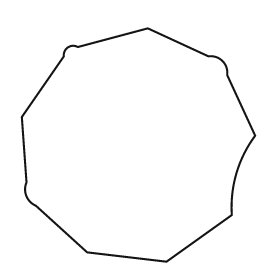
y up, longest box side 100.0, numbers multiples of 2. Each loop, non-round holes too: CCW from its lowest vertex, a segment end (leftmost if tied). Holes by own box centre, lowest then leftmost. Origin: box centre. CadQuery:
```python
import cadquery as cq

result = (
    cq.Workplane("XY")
    .moveTo(12.0, -50.0)
    .lineTo(40.0, -30.0)
    .threePointArc((42.0, -12.0), (50.0, 4.0))
    .lineTo(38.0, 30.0)
    .threePointArc((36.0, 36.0), (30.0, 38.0))
    .lineTo(4.0, 50.0)
    .lineTo(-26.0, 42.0)
    .threePointArc((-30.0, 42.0), (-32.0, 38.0))
    .lineTo(-50.0, 12.0)
    .lineTo(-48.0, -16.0)
    .threePointArc((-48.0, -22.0), (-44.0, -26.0))
    .lineTo(-22.0, -46.0)
    .close()
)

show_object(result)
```